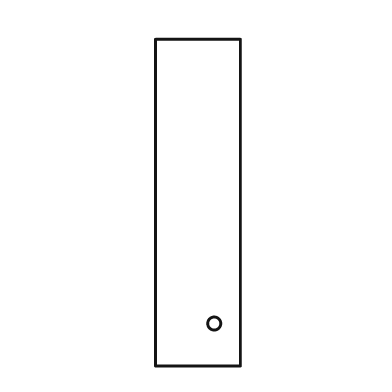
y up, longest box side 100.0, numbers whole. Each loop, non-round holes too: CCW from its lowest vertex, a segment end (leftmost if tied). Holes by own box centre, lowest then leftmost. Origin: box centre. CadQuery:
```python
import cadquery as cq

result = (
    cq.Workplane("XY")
    .moveTo(-13.0, -50.0)
    .lineTo(13.0, -50.0)
    .lineTo(13.0, 50.0)
    .lineTo(-13.0, 50.0)
    .close()
    .moveTo(5.0, -37.0)
    .circle(2.0)
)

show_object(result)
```